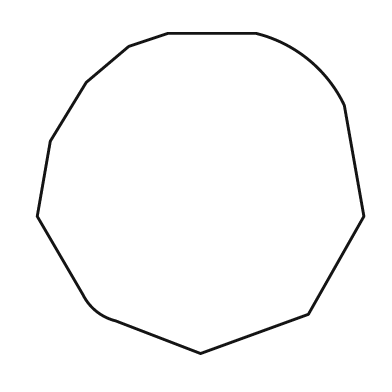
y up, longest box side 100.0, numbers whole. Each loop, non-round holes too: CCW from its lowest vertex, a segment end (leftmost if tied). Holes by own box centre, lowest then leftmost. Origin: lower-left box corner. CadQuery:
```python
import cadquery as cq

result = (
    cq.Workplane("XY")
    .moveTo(50.0, 0.0)
    .lineTo(83.0, 12.0)
    .lineTo(100.0, 42.0)
    .lineTo(94.0, 76.0)
    .threePointArc((83.0, 90.0), (67.0, 98.0))
    .lineTo(40.0, 98.0)
    .lineTo(28.0, 94.0)
    .lineTo(15.0, 83.0)
    .lineTo(4.0, 65.0)
    .lineTo(0.0, 42.0)
    .lineTo(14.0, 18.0)
    .threePointArc((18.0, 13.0), (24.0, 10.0))
    .close()
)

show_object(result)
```